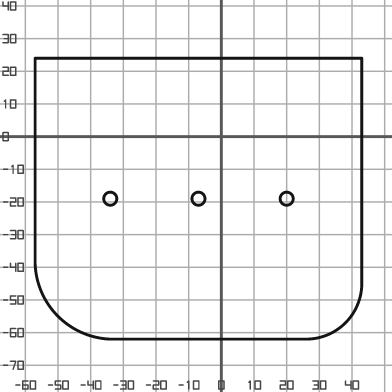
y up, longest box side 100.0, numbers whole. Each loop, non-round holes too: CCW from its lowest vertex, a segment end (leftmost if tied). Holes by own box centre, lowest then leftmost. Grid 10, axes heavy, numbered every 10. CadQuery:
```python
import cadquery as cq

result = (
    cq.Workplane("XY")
    .moveTo(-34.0, -62.0)
    .lineTo(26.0, -62.0)
    .threePointArc((38.0, -57.0), (43.0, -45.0))
    .lineTo(43.0, 24.0)
    .lineTo(-57.0, 24.0)
    .lineTo(-57.0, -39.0)
    .threePointArc((-50.0, -55.0), (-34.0, -62.0))
    .close()
    .moveTo(-34.0, -19.0)
    .circle(2.0)
    .moveTo(-7.0, -19.0)
    .circle(2.0)
    .moveTo(20.0, -19.0)
    .circle(2.0)
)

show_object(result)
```